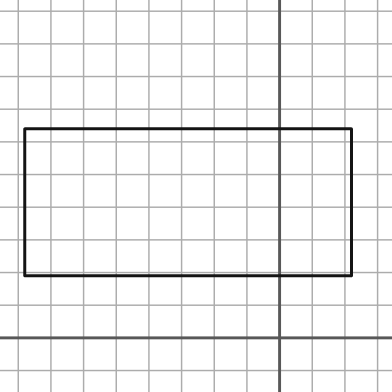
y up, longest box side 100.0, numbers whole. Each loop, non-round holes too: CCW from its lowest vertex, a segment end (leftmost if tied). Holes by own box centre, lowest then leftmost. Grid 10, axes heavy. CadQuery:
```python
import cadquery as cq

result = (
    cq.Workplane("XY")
    .moveTo(-78.0, 19.0)
    .lineTo(22.0, 19.0)
    .lineTo(22.0, 64.0)
    .lineTo(-78.0, 64.0)
    .close()
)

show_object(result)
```